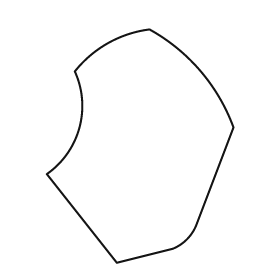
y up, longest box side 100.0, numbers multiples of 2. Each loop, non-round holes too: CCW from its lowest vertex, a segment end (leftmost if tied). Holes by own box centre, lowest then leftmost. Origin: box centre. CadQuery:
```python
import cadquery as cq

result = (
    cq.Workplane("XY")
    .moveTo(-10.0, -50.0)
    .lineTo(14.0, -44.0)
    .threePointArc((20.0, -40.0), (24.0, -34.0))
    .lineTo(40.0, 8.0)
    .threePointArc((26.0, 32.0), (4.0, 50.0))
    .threePointArc((-14.0, 44.0), (-28.0, 32.0))
    .threePointArc((-26.0, 8.0), (-40.0, -12.0))
    .close()
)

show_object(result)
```